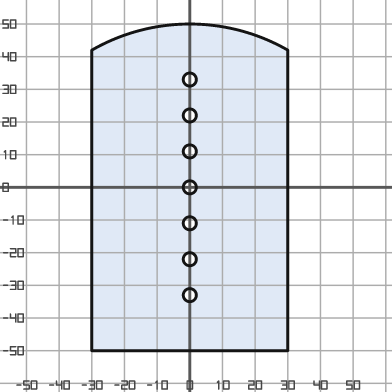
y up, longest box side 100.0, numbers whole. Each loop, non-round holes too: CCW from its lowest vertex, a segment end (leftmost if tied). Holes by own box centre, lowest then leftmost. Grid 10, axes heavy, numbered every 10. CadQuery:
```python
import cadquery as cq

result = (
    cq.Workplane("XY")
    .moveTo(-30.0, -50.0)
    .lineTo(30.0, -50.0)
    .lineTo(30.0, 42.0)
    .threePointArc((0.0, 50.0), (-30.0, 42.0))
    .close()
    .moveTo(0.0, -33.0)
    .circle(2.0)
    .moveTo(0.0, -22.0)
    .circle(2.0)
    .moveTo(0.0, -11.0)
    .circle(2.0)
    .moveTo(0.0, 0.0)
    .circle(2.0)
    .moveTo(0.0, 11.0)
    .circle(2.0)
    .moveTo(0.0, 22.0)
    .circle(2.0)
    .moveTo(0.0, 33.0)
    .circle(2.0)
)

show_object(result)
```